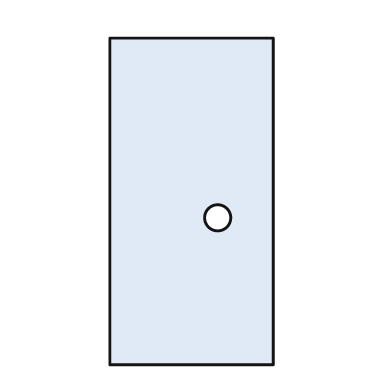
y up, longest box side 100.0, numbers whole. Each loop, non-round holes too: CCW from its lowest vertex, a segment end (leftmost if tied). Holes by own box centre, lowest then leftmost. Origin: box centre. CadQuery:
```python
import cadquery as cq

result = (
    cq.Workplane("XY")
    .moveTo(-25.0, -50.0)
    .lineTo(25.0, -50.0)
    .lineTo(25.0, 50.0)
    .lineTo(-25.0, 50.0)
    .close()
    .moveTo(8.0, -5.0)
    .circle(4.0)
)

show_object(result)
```